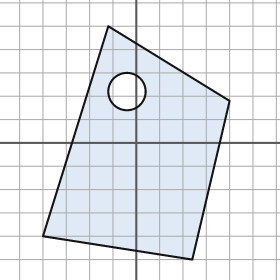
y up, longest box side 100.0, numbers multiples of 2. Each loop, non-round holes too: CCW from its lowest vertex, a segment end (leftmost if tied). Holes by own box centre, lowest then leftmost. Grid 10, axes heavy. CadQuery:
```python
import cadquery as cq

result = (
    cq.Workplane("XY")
    .moveTo(24.0, -50.0)
    .lineTo(40.0, 18.0)
    .lineTo(-12.0, 50.0)
    .lineTo(-40.0, -40.0)
    .close()
    .moveTo(-4.0, 22.0)
    .circle(8.0)
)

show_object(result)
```